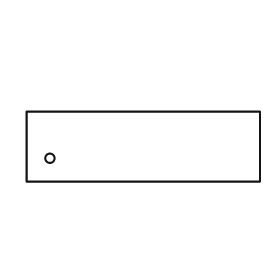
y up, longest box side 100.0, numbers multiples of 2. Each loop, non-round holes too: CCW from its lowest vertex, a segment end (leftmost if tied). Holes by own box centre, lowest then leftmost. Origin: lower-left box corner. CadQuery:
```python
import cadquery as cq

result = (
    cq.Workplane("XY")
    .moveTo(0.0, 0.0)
    .lineTo(100.0, 0.0)
    .lineTo(100.0, 30.0)
    .lineTo(0.0, 30.0)
    .close()
    .moveTo(10.0, 10.0)
    .circle(2.0)
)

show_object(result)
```